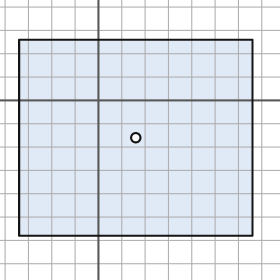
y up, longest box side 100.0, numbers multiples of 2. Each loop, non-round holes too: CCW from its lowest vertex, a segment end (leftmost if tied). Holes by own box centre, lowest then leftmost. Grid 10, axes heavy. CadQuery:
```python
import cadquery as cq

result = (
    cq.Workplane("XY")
    .moveTo(-34.0, -58.0)
    .lineTo(66.0, -58.0)
    .lineTo(66.0, 26.0)
    .lineTo(-34.0, 26.0)
    .close()
    .moveTo(16.0, -16.0)
    .circle(2.0)
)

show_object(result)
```